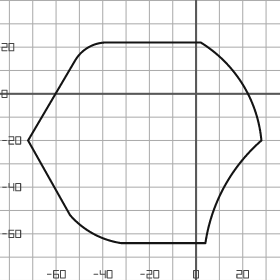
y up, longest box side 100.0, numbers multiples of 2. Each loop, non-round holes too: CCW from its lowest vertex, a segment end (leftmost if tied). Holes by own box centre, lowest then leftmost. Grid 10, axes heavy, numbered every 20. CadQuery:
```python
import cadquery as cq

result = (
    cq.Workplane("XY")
    .moveTo(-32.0, -64.0)
    .lineTo(4.0, -64.0)
    .threePointArc((12.0, -40.0), (28.0, -20.0))
    .threePointArc((20.0, 4.0), (2.0, 22.0))
    .lineTo(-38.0, 22.0)
    .threePointArc((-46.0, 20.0), (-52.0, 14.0))
    .lineTo(-72.0, -20.0)
    .lineTo(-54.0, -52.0)
    .threePointArc((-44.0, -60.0), (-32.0, -64.0))
    .close()
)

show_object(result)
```